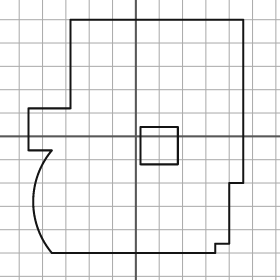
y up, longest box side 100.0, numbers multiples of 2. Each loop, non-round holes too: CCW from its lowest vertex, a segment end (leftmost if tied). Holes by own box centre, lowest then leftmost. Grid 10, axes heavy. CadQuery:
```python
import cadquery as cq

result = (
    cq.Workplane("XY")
    .moveTo(-36.0, -50.0)
    .lineTo(34.0, -50.0)
    .lineTo(34.0, -46.0)
    .lineTo(40.0, -46.0)
    .lineTo(40.0, -20.0)
    .lineTo(46.0, -20.0)
    .lineTo(46.0, 50.0)
    .lineTo(-28.0, 50.0)
    .lineTo(-28.0, 12.0)
    .lineTo(-46.0, 12.0)
    .lineTo(-46.0, -6.0)
    .lineTo(-36.0, -6.0)
    .threePointArc((-44.0, -28.0), (-36.0, -50.0))
    .close()
    .moveTo(2.0, -12.0)
    .lineTo(18.0, -12.0)
    .lineTo(18.0, 4.0)
    .lineTo(2.0, 4.0)
    .close()
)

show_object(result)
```